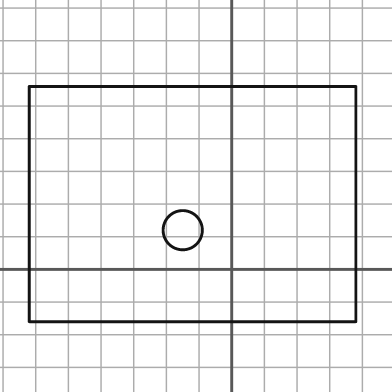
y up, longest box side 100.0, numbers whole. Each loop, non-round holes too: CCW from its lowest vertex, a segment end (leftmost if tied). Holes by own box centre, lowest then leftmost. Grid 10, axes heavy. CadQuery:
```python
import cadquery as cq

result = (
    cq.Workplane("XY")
    .moveTo(-62.0, -16.0)
    .lineTo(38.0, -16.0)
    .lineTo(38.0, 56.0)
    .lineTo(-62.0, 56.0)
    .close()
    .moveTo(-15.0, 12.0)
    .circle(6.0)
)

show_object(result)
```